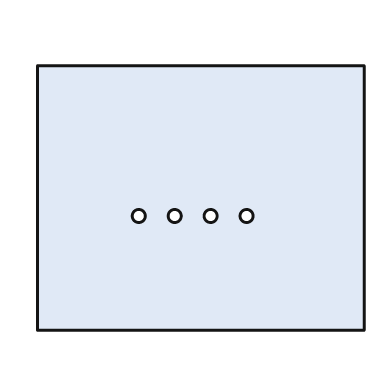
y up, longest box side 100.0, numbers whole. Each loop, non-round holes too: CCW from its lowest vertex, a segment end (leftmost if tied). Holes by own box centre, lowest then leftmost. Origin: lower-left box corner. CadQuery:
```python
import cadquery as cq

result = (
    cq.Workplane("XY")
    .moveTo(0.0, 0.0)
    .lineTo(100.0, 0.0)
    .lineTo(100.0, 81.0)
    .lineTo(0.0, 81.0)
    .close()
    .moveTo(31.0, 35.0)
    .circle(2.0)
    .moveTo(42.0, 35.0)
    .circle(2.0)
    .moveTo(53.0, 35.0)
    .circle(2.0)
    .moveTo(64.0, 35.0)
    .circle(2.0)
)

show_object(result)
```